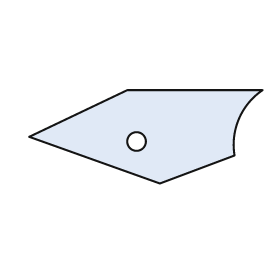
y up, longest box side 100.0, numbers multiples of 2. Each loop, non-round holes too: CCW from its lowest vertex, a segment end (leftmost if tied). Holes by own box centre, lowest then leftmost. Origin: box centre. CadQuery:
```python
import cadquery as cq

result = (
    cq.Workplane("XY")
    .moveTo(6.0, -20.0)
    .lineTo(38.0, -8.0)
    .threePointArc((40.0, 8.0), (50.0, 20.0))
    .lineTo(-8.0, 20.0)
    .lineTo(-50.0, 0.0)
    .close()
    .moveTo(-4.0, -2.0)
    .circle(4.0)
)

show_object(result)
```